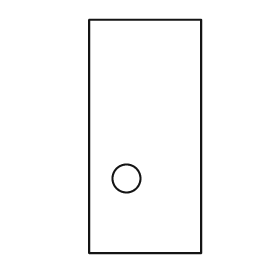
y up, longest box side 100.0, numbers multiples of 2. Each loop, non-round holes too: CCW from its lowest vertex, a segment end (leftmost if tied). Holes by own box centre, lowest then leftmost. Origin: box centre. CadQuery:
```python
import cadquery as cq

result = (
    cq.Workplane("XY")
    .moveTo(-24.0, -50.0)
    .lineTo(24.0, -50.0)
    .lineTo(24.0, 50.0)
    .lineTo(-24.0, 50.0)
    .close()
    .moveTo(-8.0, -18.0)
    .circle(6.0)
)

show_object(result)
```